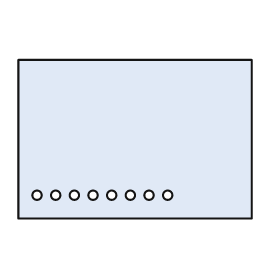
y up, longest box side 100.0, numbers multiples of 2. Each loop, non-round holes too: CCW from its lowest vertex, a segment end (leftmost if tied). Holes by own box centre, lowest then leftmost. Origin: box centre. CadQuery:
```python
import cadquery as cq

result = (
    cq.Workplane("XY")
    .moveTo(-50.0, -34.0)
    .lineTo(50.0, -34.0)
    .lineTo(50.0, 34.0)
    .lineTo(-50.0, 34.0)
    .close()
    .moveTo(-42.0, -24.0)
    .circle(2.0)
    .moveTo(-34.0, -24.0)
    .circle(2.0)
    .moveTo(-26.0, -24.0)
    .circle(2.0)
    .moveTo(-18.0, -24.0)
    .circle(2.0)
    .moveTo(-10.0, -24.0)
    .circle(2.0)
    .moveTo(-2.0, -24.0)
    .circle(2.0)
    .moveTo(6.0, -24.0)
    .circle(2.0)
    .moveTo(14.0, -24.0)
    .circle(2.0)
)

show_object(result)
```